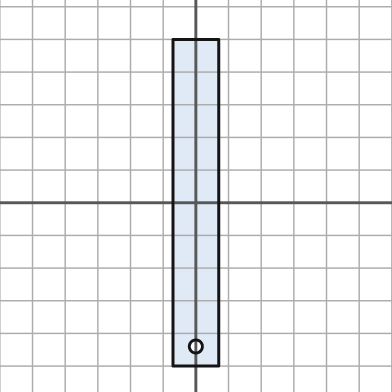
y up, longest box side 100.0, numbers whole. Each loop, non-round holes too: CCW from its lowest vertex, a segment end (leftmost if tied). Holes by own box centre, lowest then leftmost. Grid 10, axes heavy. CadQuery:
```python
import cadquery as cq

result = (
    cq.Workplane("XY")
    .moveTo(-7.0, -50.0)
    .lineTo(7.0, -50.0)
    .lineTo(7.0, 50.0)
    .lineTo(-7.0, 50.0)
    .close()
    .moveTo(0.0, -44.0)
    .circle(2.0)
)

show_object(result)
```